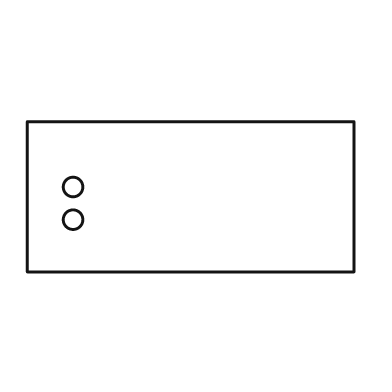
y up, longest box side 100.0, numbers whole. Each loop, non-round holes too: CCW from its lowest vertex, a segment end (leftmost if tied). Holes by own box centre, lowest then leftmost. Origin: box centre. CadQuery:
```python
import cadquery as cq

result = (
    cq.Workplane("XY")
    .moveTo(-50.0, -23.0)
    .lineTo(50.0, -23.0)
    .lineTo(50.0, 23.0)
    .lineTo(-50.0, 23.0)
    .close()
    .moveTo(-36.0, -7.0)
    .circle(3.0)
    .moveTo(-36.0, 3.0)
    .circle(3.0)
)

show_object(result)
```